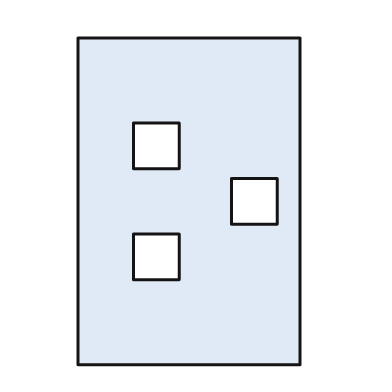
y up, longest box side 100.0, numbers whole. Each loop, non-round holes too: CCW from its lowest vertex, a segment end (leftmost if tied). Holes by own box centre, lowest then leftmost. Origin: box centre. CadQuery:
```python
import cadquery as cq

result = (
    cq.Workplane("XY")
    .moveTo(-34.0, -50.0)
    .lineTo(34.0, -50.0)
    .lineTo(34.0, 50.0)
    .lineTo(-34.0, 50.0)
    .close()
    .moveTo(-17.0, -24.0)
    .lineTo(-3.0, -24.0)
    .lineTo(-3.0, -10.0)
    .lineTo(-17.0, -10.0)
    .close()
    .moveTo(13.0, -7.0)
    .lineTo(27.0, -7.0)
    .lineTo(27.0, 7.0)
    .lineTo(13.0, 7.0)
    .close()
    .moveTo(-17.0, 10.0)
    .lineTo(-3.0, 10.0)
    .lineTo(-3.0, 24.0)
    .lineTo(-17.0, 24.0)
    .close()
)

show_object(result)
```